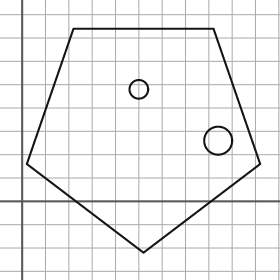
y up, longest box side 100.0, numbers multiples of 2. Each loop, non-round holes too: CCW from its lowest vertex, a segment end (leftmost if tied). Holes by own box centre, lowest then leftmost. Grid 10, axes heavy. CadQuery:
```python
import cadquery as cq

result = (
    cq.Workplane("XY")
    .moveTo(52.0, -22.0)
    .lineTo(102.0, 16.0)
    .lineTo(82.0, 74.0)
    .lineTo(22.0, 74.0)
    .lineTo(2.0, 16.0)
    .close()
    .moveTo(84.0, 26.0)
    .circle(6.0)
    .moveTo(50.0, 48.0)
    .circle(4.0)
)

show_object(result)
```